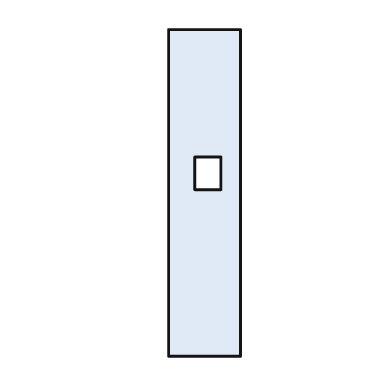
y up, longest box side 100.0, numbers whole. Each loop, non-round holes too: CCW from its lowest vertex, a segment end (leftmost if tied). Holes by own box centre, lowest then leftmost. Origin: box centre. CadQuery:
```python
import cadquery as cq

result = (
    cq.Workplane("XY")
    .moveTo(-11.0, -50.0)
    .lineTo(11.0, -50.0)
    .lineTo(11.0, 50.0)
    .lineTo(-11.0, 50.0)
    .close()
    .moveTo(-3.0, 1.0)
    .lineTo(5.0, 1.0)
    .lineTo(5.0, 11.0)
    .lineTo(-3.0, 11.0)
    .close()
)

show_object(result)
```